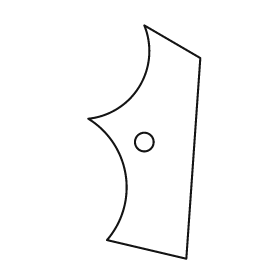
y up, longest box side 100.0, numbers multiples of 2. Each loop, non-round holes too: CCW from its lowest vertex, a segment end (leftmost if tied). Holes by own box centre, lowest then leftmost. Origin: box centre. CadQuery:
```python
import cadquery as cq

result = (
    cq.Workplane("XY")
    .moveTo(18.0, -50.0)
    .lineTo(24.0, 36.0)
    .lineTo(0.0, 50.0)
    .threePointArc((-2.0, 24.0), (-24.0, 10.0))
    .threePointArc((-8.0, -14.0), (-16.0, -42.0))
    .close()
    .moveTo(0.0, 0.0)
    .circle(4.0)
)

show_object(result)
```